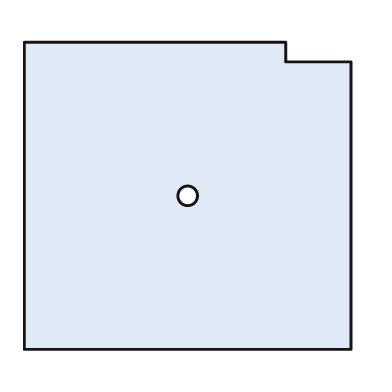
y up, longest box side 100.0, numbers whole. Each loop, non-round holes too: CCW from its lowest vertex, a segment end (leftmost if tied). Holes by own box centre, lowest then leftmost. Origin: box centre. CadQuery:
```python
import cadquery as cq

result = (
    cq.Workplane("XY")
    .moveTo(-50.0, -47.0)
    .lineTo(50.0, -47.0)
    .lineTo(50.0, 41.0)
    .lineTo(30.0, 41.0)
    .lineTo(30.0, 47.0)
    .lineTo(-50.0, 47.0)
    .close()
    .moveTo(0.0, 0.0)
    .circle(3.0)
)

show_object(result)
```